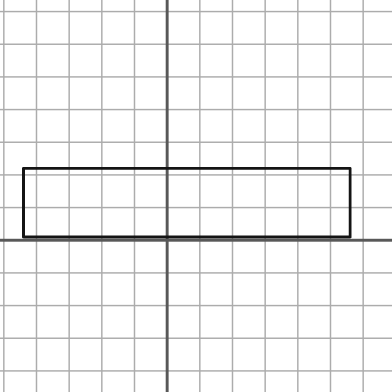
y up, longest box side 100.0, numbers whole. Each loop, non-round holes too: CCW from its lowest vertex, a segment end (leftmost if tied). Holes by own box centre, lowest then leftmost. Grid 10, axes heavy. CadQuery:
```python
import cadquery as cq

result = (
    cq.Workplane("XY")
    .moveTo(-44.0, 1.0)
    .lineTo(56.0, 1.0)
    .lineTo(56.0, 22.0)
    .lineTo(-44.0, 22.0)
    .close()
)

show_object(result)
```